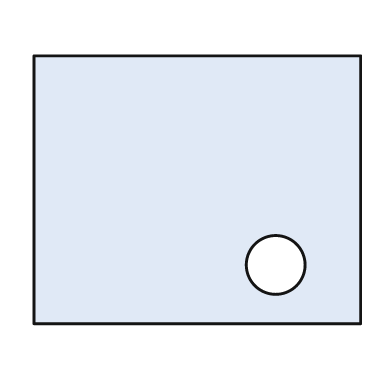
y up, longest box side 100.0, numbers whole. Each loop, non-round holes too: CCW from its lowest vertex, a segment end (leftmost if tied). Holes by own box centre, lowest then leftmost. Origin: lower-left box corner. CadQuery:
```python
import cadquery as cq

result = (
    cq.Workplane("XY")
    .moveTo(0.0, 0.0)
    .lineTo(100.0, 0.0)
    .lineTo(100.0, 82.0)
    .lineTo(0.0, 82.0)
    .close()
    .moveTo(74.0, 18.0)
    .circle(9.0)
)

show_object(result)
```